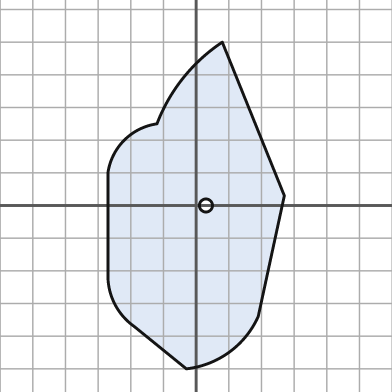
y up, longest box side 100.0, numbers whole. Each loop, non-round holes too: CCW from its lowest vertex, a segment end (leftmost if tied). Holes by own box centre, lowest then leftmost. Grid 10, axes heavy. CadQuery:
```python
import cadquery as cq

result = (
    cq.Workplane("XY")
    .moveTo(-3.0, -50.0)
    .threePointArc((10.0, -45.0), (19.0, -34.0))
    .lineTo(27.0, 3.0)
    .lineTo(8.0, 50.0)
    .threePointArc((-4.0, 39.0), (-12.0, 25.0))
    .threePointArc((-22.0, 20.0), (-27.0, 10.0))
    .lineTo(-27.0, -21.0)
    .threePointArc((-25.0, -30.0), (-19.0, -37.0))
    .close()
    .moveTo(3.0, 0.0)
    .circle(2.0)
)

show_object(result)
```